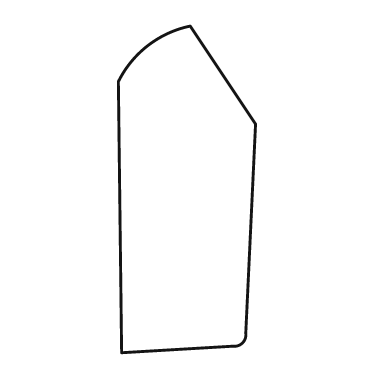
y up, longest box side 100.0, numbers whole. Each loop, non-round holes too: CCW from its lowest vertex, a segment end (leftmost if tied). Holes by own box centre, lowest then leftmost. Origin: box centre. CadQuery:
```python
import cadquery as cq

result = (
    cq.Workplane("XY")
    .moveTo(-20.0, -50.0)
    .lineTo(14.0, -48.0)
    .threePointArc((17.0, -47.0), (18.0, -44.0))
    .lineTo(21.0, 20.0)
    .lineTo(1.0, 50.0)
    .threePointArc((-12.0, 44.0), (-21.0, 33.0))
    .close()
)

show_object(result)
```